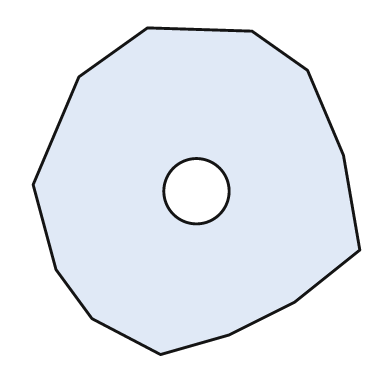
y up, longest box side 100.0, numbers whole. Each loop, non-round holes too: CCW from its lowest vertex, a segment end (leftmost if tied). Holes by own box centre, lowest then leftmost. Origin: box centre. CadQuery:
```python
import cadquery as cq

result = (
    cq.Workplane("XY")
    .moveTo(-11.0, -50.0)
    .lineTo(10.0, -44.0)
    .lineTo(30.0, -34.0)
    .lineTo(50.0, -18.0)
    .lineTo(45.0, 11.0)
    .lineTo(34.0, 37.0)
    .lineTo(17.0, 49.0)
    .lineTo(-15.0, 50.0)
    .lineTo(-36.0, 35.0)
    .lineTo(-50.0, 2.0)
    .lineTo(-43.0, -24.0)
    .lineTo(-32.0, -39.0)
    .close()
    .moveTo(0.0, 0.0)
    .circle(10.0)
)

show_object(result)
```